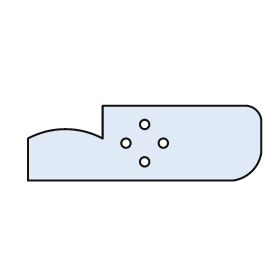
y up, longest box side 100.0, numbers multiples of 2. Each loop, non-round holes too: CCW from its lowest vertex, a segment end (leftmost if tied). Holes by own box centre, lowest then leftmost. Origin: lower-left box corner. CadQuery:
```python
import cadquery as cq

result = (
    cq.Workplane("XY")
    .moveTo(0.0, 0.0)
    .lineTo(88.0, 0.0)
    .threePointArc((96.0, 4.0), (100.0, 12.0))
    .lineTo(100.0, 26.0)
    .threePointArc((98.0, 30.0), (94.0, 32.0))
    .lineTo(32.0, 32.0)
    .lineTo(32.0, 18.0)
    .threePointArc((16.0, 22.0), (0.0, 18.0))
    .close()
    .moveTo(50.0, 8.0)
    .circle(2.0)
    .moveTo(42.0, 16.0)
    .circle(2.0)
    .moveTo(58.0, 16.0)
    .circle(2.0)
    .moveTo(50.0, 24.0)
    .circle(2.0)
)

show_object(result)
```